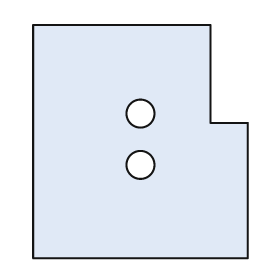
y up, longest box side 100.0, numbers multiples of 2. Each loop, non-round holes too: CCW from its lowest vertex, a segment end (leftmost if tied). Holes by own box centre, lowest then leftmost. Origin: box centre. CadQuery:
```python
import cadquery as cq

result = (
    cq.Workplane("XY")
    .moveTo(-46.0, -50.0)
    .lineTo(46.0, -50.0)
    .lineTo(46.0, 8.0)
    .lineTo(30.0, 8.0)
    .lineTo(30.0, 50.0)
    .lineTo(-46.0, 50.0)
    .close()
    .moveTo(0.0, -10.0)
    .circle(6.0)
    .moveTo(0.0, 12.0)
    .circle(6.0)
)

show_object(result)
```